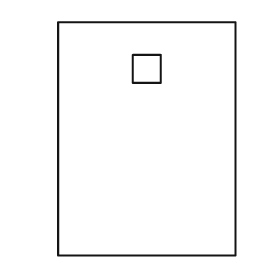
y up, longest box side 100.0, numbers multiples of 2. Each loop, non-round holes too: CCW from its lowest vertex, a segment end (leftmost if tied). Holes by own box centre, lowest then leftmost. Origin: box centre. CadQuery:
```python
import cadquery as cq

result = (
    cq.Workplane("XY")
    .moveTo(-38.0, -50.0)
    .lineTo(38.0, -50.0)
    .lineTo(38.0, 50.0)
    .lineTo(-38.0, 50.0)
    .close()
    .moveTo(-6.0, 24.0)
    .lineTo(6.0, 24.0)
    .lineTo(6.0, 36.0)
    .lineTo(-6.0, 36.0)
    .close()
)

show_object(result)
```